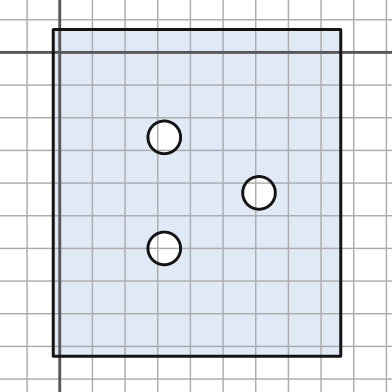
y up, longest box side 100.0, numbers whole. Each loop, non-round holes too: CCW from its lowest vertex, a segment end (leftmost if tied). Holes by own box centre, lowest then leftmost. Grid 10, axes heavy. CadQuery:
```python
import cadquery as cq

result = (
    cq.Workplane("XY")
    .moveTo(-2.0, -93.0)
    .lineTo(86.0, -93.0)
    .lineTo(86.0, 7.0)
    .lineTo(-2.0, 7.0)
    .close()
    .moveTo(32.0, -60.0)
    .circle(5.0)
    .moveTo(61.0, -43.0)
    .circle(5.0)
    .moveTo(32.0, -26.0)
    .circle(5.0)
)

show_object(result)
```